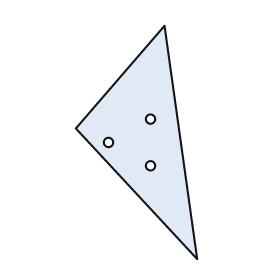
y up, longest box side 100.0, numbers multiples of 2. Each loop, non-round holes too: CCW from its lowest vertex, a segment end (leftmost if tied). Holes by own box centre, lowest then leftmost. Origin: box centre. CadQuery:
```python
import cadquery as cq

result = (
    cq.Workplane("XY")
    .moveTo(26.0, -50.0)
    .lineTo(12.0, 50.0)
    .lineTo(-26.0, 6.0)
    .close()
    .moveTo(6.0, -10.0)
    .circle(2.0)
    .moveTo(-12.0, 0.0)
    .circle(2.0)
    .moveTo(6.0, 10.0)
    .circle(2.0)
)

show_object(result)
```